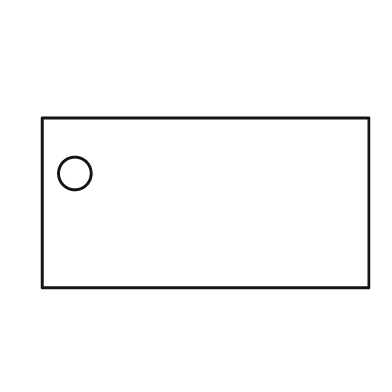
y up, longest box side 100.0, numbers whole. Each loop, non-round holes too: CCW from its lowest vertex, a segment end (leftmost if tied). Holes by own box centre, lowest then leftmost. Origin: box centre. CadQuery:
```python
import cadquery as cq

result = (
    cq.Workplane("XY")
    .moveTo(-50.0, -26.0)
    .lineTo(50.0, -26.0)
    .lineTo(50.0, 26.0)
    .lineTo(-50.0, 26.0)
    .close()
    .moveTo(-40.0, 9.0)
    .circle(5.0)
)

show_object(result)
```